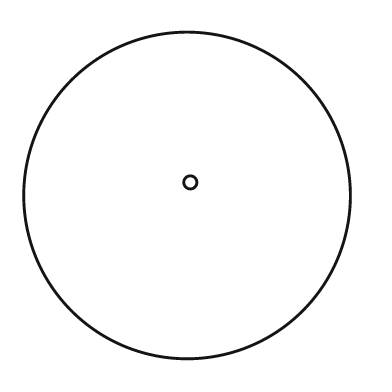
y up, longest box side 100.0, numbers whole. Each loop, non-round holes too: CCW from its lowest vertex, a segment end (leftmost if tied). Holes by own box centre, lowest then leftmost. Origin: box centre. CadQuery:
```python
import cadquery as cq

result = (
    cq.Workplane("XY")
    .moveTo(0.0, 0.0)
    .circle(50.0)
    .moveTo(1.0, 4.0)
    .circle(2.0)
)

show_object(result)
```